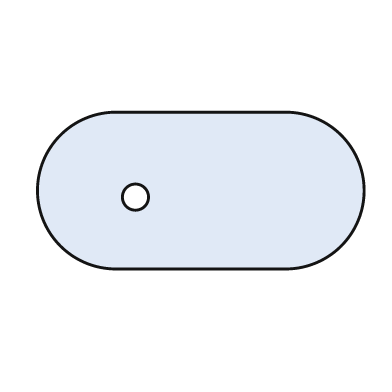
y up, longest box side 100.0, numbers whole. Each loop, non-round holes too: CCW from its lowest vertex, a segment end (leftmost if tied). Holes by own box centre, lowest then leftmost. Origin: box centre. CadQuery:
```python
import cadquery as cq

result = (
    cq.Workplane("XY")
    .moveTo(-26.0, -24.0)
    .lineTo(26.0, -24.0)
    .threePointArc((50.0, 0.0), (26.0, 24.0))
    .lineTo(-26.0, 24.0)
    .threePointArc((-50.0, 0.0), (-26.0, -24.0))
    .close()
    .moveTo(-20.0, -2.0)
    .circle(4.0)
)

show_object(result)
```